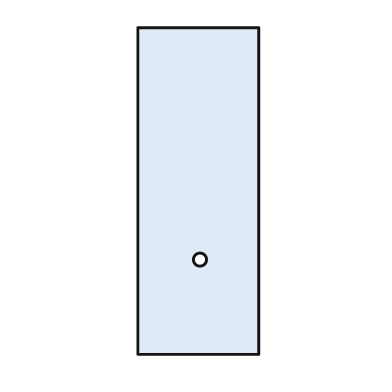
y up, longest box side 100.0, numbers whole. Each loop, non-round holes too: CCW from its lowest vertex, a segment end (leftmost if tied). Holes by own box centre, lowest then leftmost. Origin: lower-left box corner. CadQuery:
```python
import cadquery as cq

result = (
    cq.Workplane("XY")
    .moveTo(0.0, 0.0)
    .lineTo(37.0, 0.0)
    .lineTo(37.0, 100.0)
    .lineTo(0.0, 100.0)
    .close()
    .moveTo(19.0, 29.0)
    .circle(2.0)
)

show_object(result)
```